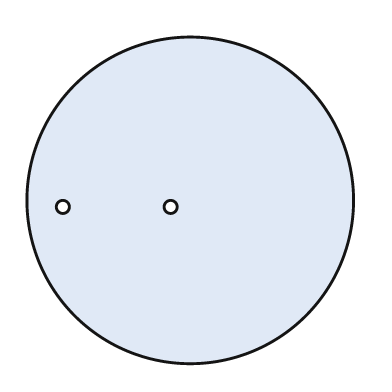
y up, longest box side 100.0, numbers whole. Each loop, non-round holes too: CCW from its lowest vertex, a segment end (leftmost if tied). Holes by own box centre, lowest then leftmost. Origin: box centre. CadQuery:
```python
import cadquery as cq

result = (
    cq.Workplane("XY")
    .moveTo(0.0, 0.0)
    .circle(50.0)
    .moveTo(-39.0, -2.0)
    .circle(2.0)
    .moveTo(-6.0, -2.0)
    .circle(2.0)
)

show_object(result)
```